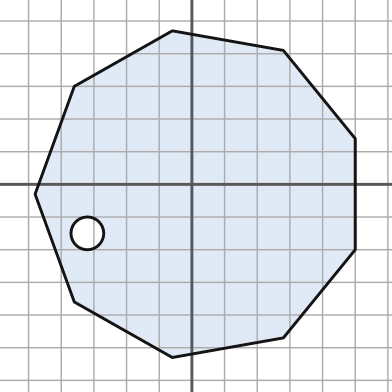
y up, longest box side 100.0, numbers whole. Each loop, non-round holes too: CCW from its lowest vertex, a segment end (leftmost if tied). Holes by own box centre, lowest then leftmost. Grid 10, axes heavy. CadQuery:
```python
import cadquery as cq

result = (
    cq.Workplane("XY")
    .moveTo(-6.0, -53.0)
    .lineTo(28.0, -47.0)
    .lineTo(50.0, -20.0)
    .lineTo(50.0, 14.0)
    .lineTo(28.0, 41.0)
    .lineTo(-6.0, 47.0)
    .lineTo(-36.0, 30.0)
    .lineTo(-48.0, -3.0)
    .lineTo(-36.0, -36.0)
    .close()
    .moveTo(-32.0, -15.0)
    .circle(5.0)
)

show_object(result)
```